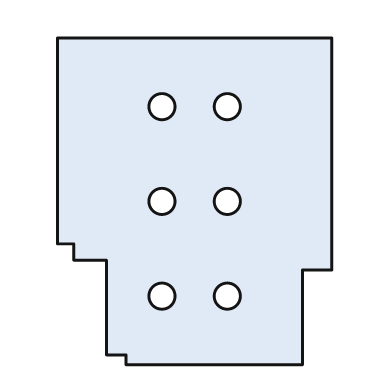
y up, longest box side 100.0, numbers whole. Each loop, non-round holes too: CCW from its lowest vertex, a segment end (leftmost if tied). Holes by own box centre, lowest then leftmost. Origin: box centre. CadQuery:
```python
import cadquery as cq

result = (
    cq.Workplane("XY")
    .moveTo(-21.0, -50.0)
    .lineTo(33.0, -50.0)
    .lineTo(33.0, -21.0)
    .lineTo(42.0, -21.0)
    .lineTo(42.0, 50.0)
    .lineTo(-42.0, 50.0)
    .lineTo(-42.0, -13.0)
    .lineTo(-37.0, -13.0)
    .lineTo(-37.0, -18.0)
    .lineTo(-27.0, -18.0)
    .lineTo(-27.0, -47.0)
    .lineTo(-21.0, -47.0)
    .close()
    .moveTo(-10.0, -29.0)
    .circle(4.0)
    .moveTo(10.0, -29.0)
    .circle(4.0)
    .moveTo(-10.0, 0.0)
    .circle(4.0)
    .moveTo(10.0, 0.0)
    .circle(4.0)
    .moveTo(-10.0, 29.0)
    .circle(4.0)
    .moveTo(10.0, 29.0)
    .circle(4.0)
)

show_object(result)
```